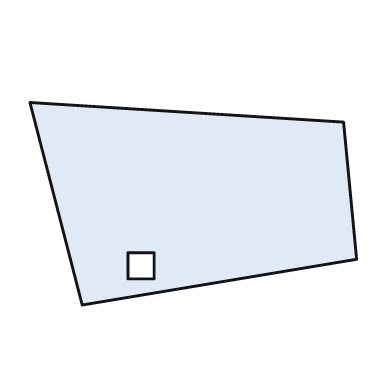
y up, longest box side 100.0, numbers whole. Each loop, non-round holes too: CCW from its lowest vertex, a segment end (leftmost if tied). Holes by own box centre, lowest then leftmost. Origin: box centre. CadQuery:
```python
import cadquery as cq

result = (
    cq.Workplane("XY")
    .moveTo(-34.0, -31.0)
    .lineTo(50.0, -17.0)
    .lineTo(46.0, 25.0)
    .lineTo(-50.0, 31.0)
    .close()
    .moveTo(-20.0, -23.0)
    .lineTo(-12.0, -23.0)
    .lineTo(-12.0, -15.0)
    .lineTo(-20.0, -15.0)
    .close()
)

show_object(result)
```